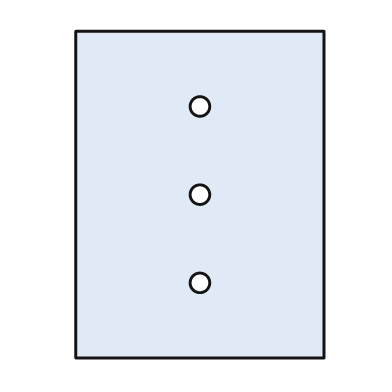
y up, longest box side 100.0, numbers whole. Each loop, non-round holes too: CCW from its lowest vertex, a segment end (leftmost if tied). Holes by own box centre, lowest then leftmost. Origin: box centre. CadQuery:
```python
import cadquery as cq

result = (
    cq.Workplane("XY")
    .moveTo(-38.0, -50.0)
    .lineTo(38.0, -50.0)
    .lineTo(38.0, 50.0)
    .lineTo(-38.0, 50.0)
    .close()
    .moveTo(0.0, -27.0)
    .circle(3.0)
    .moveTo(0.0, 0.0)
    .circle(3.0)
    .moveTo(0.0, 27.0)
    .circle(3.0)
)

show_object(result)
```